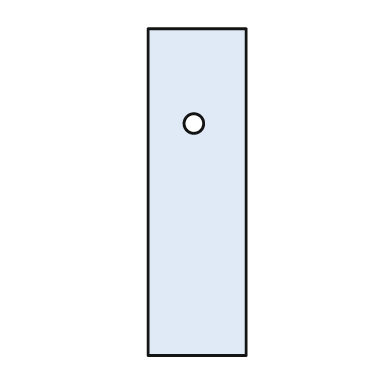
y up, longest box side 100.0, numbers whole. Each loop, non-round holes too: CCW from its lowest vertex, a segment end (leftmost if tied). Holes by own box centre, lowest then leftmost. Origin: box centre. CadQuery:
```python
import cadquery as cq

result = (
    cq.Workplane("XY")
    .moveTo(-15.0, -50.0)
    .lineTo(15.0, -50.0)
    .lineTo(15.0, 50.0)
    .lineTo(-15.0, 50.0)
    .close()
    .moveTo(-1.0, 21.0)
    .circle(3.0)
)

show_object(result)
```